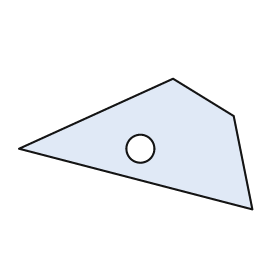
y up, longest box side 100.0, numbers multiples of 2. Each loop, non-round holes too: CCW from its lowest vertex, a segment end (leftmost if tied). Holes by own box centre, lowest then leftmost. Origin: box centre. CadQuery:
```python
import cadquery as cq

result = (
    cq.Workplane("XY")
    .moveTo(50.0, -28.0)
    .lineTo(42.0, 12.0)
    .lineTo(16.0, 28.0)
    .lineTo(-50.0, -2.0)
    .close()
    .moveTo(2.0, -2.0)
    .circle(6.0)
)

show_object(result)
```